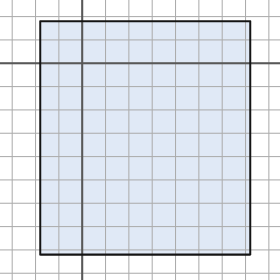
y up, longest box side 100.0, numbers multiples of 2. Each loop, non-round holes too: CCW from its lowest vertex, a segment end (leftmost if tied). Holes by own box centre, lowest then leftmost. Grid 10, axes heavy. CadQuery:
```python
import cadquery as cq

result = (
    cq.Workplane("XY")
    .moveTo(-18.0, -82.0)
    .lineTo(72.0, -82.0)
    .lineTo(72.0, 18.0)
    .lineTo(-18.0, 18.0)
    .close()
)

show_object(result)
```